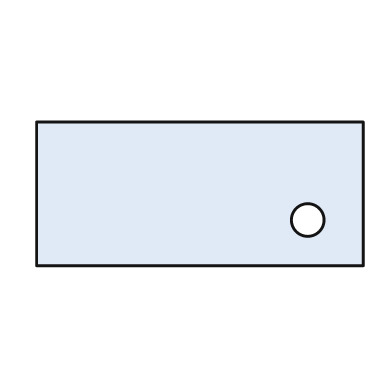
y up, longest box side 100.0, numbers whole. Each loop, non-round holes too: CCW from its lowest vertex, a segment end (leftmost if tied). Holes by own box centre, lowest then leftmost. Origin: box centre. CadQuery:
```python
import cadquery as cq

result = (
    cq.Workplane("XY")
    .moveTo(-50.0, -22.0)
    .lineTo(50.0, -22.0)
    .lineTo(50.0, 22.0)
    .lineTo(-50.0, 22.0)
    .close()
    .moveTo(33.0, -8.0)
    .circle(5.0)
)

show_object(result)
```